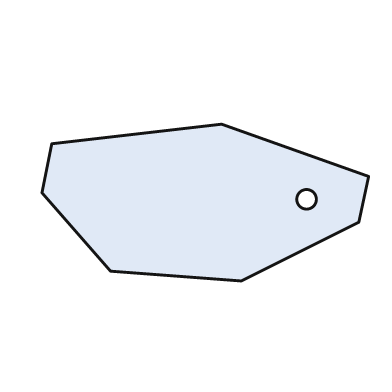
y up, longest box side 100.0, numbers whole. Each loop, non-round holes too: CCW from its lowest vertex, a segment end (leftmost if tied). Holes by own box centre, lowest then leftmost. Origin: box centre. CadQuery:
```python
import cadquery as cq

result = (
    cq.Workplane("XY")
    .moveTo(11.0, -24.0)
    .lineTo(47.0, -6.0)
    .lineTo(50.0, 8.0)
    .lineTo(5.0, 24.0)
    .lineTo(-47.0, 18.0)
    .lineTo(-50.0, 3.0)
    .lineTo(-29.0, -21.0)
    .close()
    .moveTo(31.0, 1.0)
    .circle(3.0)
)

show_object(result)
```